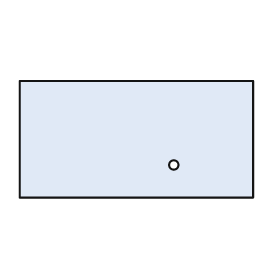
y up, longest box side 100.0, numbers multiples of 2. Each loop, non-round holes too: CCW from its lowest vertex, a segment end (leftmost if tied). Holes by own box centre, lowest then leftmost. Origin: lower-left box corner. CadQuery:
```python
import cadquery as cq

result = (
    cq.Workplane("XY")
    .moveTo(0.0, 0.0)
    .lineTo(100.0, 0.0)
    .lineTo(100.0, 50.0)
    .lineTo(0.0, 50.0)
    .close()
    .moveTo(66.0, 14.0)
    .circle(2.0)
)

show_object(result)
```